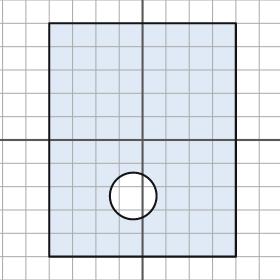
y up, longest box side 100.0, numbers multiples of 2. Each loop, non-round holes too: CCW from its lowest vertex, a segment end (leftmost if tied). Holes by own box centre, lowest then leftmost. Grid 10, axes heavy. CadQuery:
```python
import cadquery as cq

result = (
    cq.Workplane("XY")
    .moveTo(-40.0, -50.0)
    .lineTo(40.0, -50.0)
    .lineTo(40.0, 50.0)
    .lineTo(-40.0, 50.0)
    .close()
    .moveTo(-4.0, -24.0)
    .circle(10.0)
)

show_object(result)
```